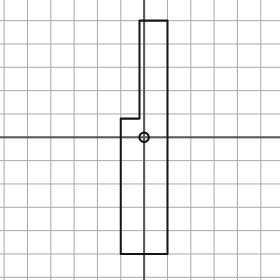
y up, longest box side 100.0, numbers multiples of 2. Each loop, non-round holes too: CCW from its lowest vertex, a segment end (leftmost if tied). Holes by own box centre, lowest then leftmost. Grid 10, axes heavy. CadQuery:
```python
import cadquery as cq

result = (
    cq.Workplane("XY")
    .moveTo(-10.0, -50.0)
    .lineTo(10.0, -50.0)
    .lineTo(10.0, 50.0)
    .lineTo(-2.0, 50.0)
    .lineTo(-2.0, 8.0)
    .lineTo(-10.0, 8.0)
    .close()
    .moveTo(0.0, 0.0)
    .circle(2.0)
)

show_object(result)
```